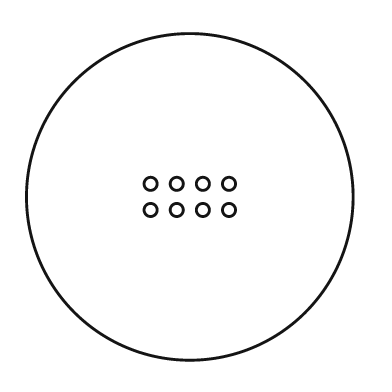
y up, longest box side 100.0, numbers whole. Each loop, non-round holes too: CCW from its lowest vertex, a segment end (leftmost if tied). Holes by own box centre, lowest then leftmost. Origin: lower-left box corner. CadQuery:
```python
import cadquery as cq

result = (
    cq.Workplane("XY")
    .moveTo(50.0, 50.0)
    .circle(50.0)
    .moveTo(38.0, 46.0)
    .circle(2.0)
    .moveTo(46.0, 46.0)
    .circle(2.0)
    .moveTo(54.0, 46.0)
    .circle(2.0)
    .moveTo(62.0, 46.0)
    .circle(2.0)
    .moveTo(38.0, 54.0)
    .circle(2.0)
    .moveTo(46.0, 54.0)
    .circle(2.0)
    .moveTo(54.0, 54.0)
    .circle(2.0)
    .moveTo(62.0, 54.0)
    .circle(2.0)
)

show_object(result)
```